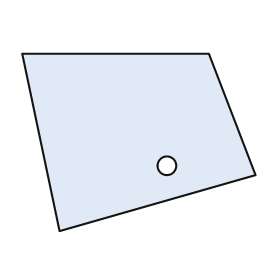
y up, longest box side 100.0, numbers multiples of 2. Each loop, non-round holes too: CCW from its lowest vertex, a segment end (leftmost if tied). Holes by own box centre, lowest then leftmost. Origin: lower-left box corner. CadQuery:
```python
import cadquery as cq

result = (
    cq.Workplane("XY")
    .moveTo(16.0, 0.0)
    .lineTo(100.0, 24.0)
    .lineTo(80.0, 76.0)
    .lineTo(0.0, 76.0)
    .close()
    .moveTo(62.0, 28.0)
    .circle(4.0)
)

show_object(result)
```